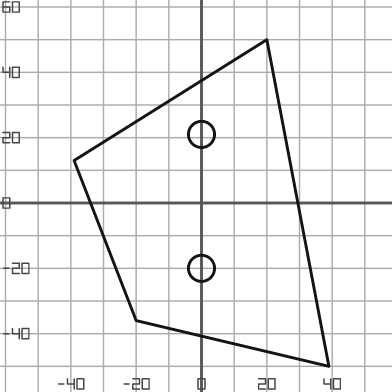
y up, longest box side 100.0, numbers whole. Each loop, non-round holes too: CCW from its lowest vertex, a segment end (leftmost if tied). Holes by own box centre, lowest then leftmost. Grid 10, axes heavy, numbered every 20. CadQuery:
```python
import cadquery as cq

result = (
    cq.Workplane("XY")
    .moveTo(39.0, -50.0)
    .lineTo(20.0, 50.0)
    .lineTo(-39.0, 13.0)
    .lineTo(-20.0, -36.0)
    .close()
    .moveTo(0.0, -20.0)
    .circle(4.0)
    .moveTo(0.0, 21.0)
    .circle(4.0)
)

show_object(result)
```